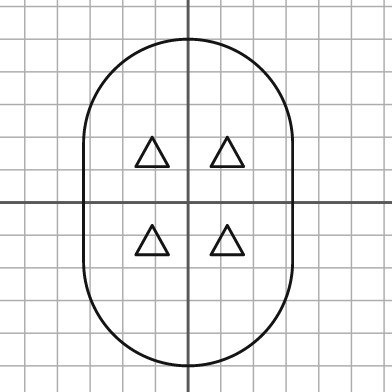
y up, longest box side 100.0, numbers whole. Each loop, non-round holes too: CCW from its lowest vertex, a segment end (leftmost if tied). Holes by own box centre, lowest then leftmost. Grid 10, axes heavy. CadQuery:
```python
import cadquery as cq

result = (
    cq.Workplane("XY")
    .moveTo(-32.0, -18.0)
    .threePointArc((0.0, -50.0), (32.0, -18.0))
    .lineTo(32.0, 18.0)
    .threePointArc((0.0, 50.0), (-32.0, 18.0))
    .close()
    .moveTo(-16.0, -16.0)
    .lineTo(-6.0, -16.0)
    .lineTo(-11.0, -7.0)
    .close()
    .moveTo(7.0, -16.0)
    .lineTo(17.0, -16.0)
    .lineTo(12.0, -7.0)
    .close()
    .moveTo(-16.0, 11.0)
    .lineTo(-6.0, 11.0)
    .lineTo(-11.0, 20.0)
    .close()
    .moveTo(7.0, 11.0)
    .lineTo(17.0, 11.0)
    .lineTo(12.0, 20.0)
    .close()
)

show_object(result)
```